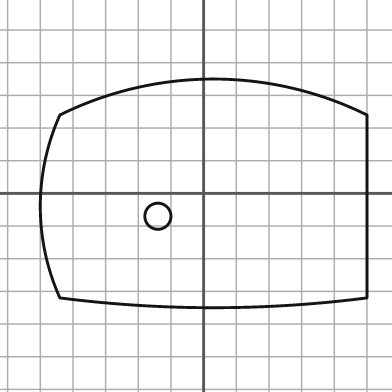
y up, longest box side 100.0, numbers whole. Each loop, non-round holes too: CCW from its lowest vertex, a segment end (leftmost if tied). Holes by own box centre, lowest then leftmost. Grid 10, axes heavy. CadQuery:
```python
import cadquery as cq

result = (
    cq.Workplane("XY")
    .moveTo(-44.0, -32.0)
    .threePointArc((3.0, -35.0), (50.0, -32.0))
    .lineTo(50.0, 24.0)
    .threePointArc((3.0, 35.0), (-44.0, 24.0))
    .threePointArc((-50.0, -4.0), (-44.0, -32.0))
    .close()
    .moveTo(-14.0, -7.0)
    .circle(4.0)
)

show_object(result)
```